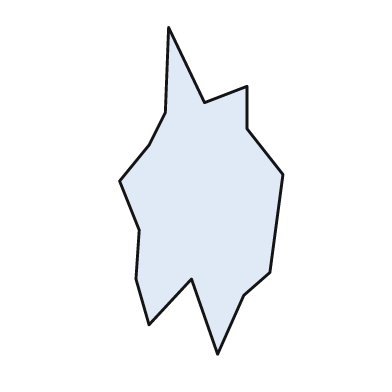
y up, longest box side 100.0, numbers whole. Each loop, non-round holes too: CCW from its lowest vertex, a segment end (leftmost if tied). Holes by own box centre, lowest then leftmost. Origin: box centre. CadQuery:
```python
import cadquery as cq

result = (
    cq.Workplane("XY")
    .moveTo(5.0, -50.0)
    .lineTo(13.0, -32.0)
    .lineTo(21.0, -25.0)
    .lineTo(25.0, 5.0)
    .lineTo(14.0, 19.0)
    .lineTo(14.0, 32.0)
    .lineTo(1.0, 27.0)
    .lineTo(-10.0, 50.0)
    .lineTo(-11.0, 24.0)
    .lineTo(-16.0, 14.0)
    .lineTo(-25.0, 3.0)
    .lineTo(-19.0, -12.0)
    .lineTo(-20.0, -27.0)
    .lineTo(-16.0, -41.0)
    .lineTo(-3.0, -27.0)
    .close()
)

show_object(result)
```